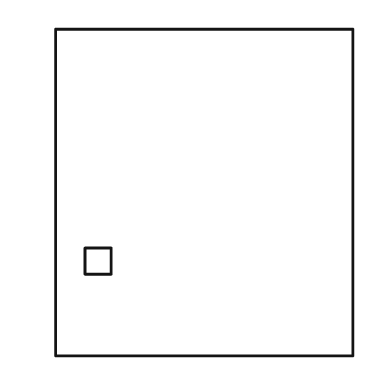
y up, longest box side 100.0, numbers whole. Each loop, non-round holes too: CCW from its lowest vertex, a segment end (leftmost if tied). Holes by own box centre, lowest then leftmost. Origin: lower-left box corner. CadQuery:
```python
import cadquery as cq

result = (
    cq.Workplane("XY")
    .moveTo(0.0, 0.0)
    .lineTo(91.0, 0.0)
    .lineTo(91.0, 100.0)
    .lineTo(0.0, 100.0)
    .close()
    .moveTo(9.0, 25.0)
    .lineTo(17.0, 25.0)
    .lineTo(17.0, 33.0)
    .lineTo(9.0, 33.0)
    .close()
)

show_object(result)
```